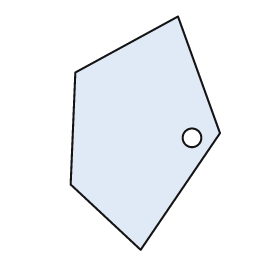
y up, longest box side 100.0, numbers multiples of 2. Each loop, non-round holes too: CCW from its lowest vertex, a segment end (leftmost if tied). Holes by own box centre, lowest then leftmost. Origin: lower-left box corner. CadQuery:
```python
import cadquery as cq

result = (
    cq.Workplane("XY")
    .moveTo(30.0, 0.0)
    .lineTo(64.0, 50.0)
    .lineTo(46.0, 100.0)
    .lineTo(2.0, 76.0)
    .lineTo(0.0, 28.0)
    .close()
    .moveTo(52.0, 48.0)
    .circle(4.0)
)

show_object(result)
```